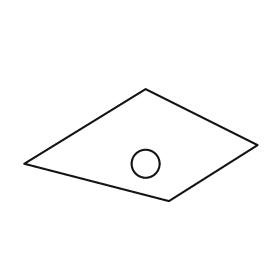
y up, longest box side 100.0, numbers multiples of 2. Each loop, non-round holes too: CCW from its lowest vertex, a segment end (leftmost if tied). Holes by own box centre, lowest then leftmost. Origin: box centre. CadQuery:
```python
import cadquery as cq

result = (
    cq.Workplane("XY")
    .moveTo(12.0, -24.0)
    .lineTo(50.0, 0.0)
    .lineTo(2.0, 24.0)
    .lineTo(-50.0, -8.0)
    .close()
    .moveTo(2.0, -8.0)
    .circle(6.0)
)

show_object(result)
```